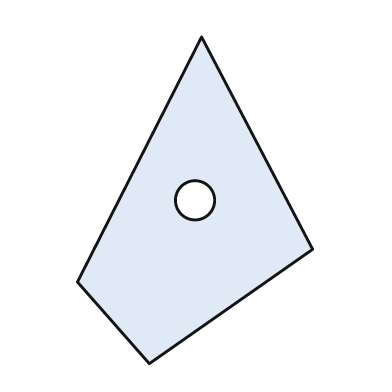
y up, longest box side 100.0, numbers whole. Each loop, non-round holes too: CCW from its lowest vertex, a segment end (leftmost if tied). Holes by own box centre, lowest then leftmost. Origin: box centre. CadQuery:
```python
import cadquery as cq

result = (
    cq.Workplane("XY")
    .moveTo(-14.0, -50.0)
    .lineTo(36.0, -15.0)
    .lineTo(2.0, 50.0)
    .lineTo(-36.0, -25.0)
    .close()
    .moveTo(0.0, 0.0)
    .circle(6.0)
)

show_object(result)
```